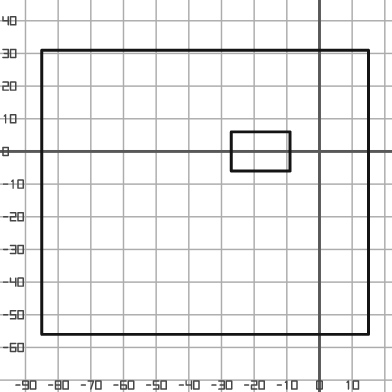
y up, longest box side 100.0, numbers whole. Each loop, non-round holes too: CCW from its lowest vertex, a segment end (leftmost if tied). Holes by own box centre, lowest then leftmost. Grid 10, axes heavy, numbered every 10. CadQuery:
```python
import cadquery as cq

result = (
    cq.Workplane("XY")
    .moveTo(-85.0, -56.0)
    .lineTo(15.0, -56.0)
    .lineTo(15.0, 31.0)
    .lineTo(-85.0, 31.0)
    .close()
    .moveTo(-27.0, -6.0)
    .lineTo(-9.0, -6.0)
    .lineTo(-9.0, 6.0)
    .lineTo(-27.0, 6.0)
    .close()
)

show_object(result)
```